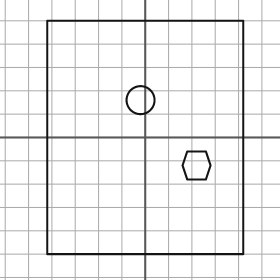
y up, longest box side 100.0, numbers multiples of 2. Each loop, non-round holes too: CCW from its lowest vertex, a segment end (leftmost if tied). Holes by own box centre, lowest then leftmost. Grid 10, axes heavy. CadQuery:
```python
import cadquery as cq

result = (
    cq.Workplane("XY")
    .moveTo(-42.0, -50.0)
    .lineTo(42.0, -50.0)
    .lineTo(42.0, 50.0)
    .lineTo(-42.0, 50.0)
    .close()
    .moveTo(18.0, -18.0)
    .lineTo(26.0, -18.0)
    .lineTo(28.0, -12.0)
    .lineTo(26.0, -6.0)
    .lineTo(18.0, -6.0)
    .lineTo(16.0, -12.0)
    .close()
    .moveTo(-2.0, 16.0)
    .circle(6.0)
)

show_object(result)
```